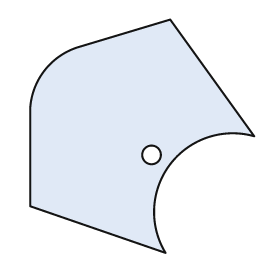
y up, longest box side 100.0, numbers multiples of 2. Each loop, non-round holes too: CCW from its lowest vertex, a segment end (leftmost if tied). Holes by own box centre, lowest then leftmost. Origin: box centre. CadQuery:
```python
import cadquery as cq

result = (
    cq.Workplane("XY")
    .moveTo(10.0, -50.0)
    .threePointArc((12.0, -12.0), (48.0, 0.0))
    .lineTo(12.0, 50.0)
    .lineTo(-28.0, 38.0)
    .threePointArc((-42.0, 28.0), (-48.0, 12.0))
    .lineTo(-48.0, -30.0)
    .close()
    .moveTo(4.0, -8.0)
    .circle(4.0)
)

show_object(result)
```